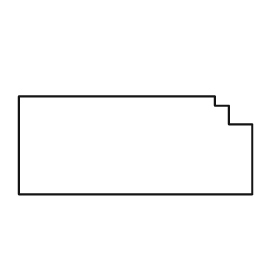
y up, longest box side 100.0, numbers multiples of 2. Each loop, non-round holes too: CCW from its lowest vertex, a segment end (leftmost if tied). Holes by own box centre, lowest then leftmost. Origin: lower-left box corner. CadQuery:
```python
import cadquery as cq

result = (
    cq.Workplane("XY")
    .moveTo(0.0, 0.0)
    .lineTo(100.0, 0.0)
    .lineTo(100.0, 30.0)
    .lineTo(90.0, 30.0)
    .lineTo(90.0, 38.0)
    .lineTo(84.0, 38.0)
    .lineTo(84.0, 42.0)
    .lineTo(0.0, 42.0)
    .close()
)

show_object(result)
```